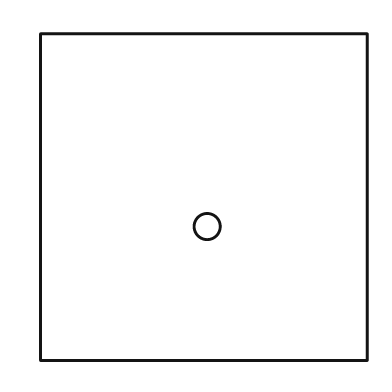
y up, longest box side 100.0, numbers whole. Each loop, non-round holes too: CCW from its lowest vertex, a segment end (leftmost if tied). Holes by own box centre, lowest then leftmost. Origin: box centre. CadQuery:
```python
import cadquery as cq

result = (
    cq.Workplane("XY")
    .moveTo(-50.0, -50.0)
    .lineTo(50.0, -50.0)
    .lineTo(50.0, 50.0)
    .lineTo(-50.0, 50.0)
    .close()
    .moveTo(1.0, -9.0)
    .circle(4.0)
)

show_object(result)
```